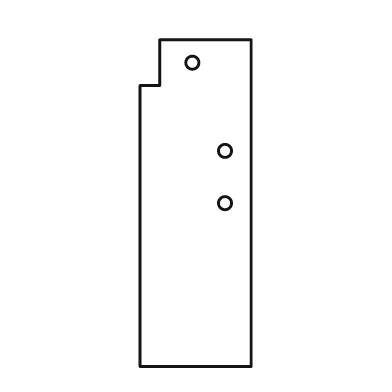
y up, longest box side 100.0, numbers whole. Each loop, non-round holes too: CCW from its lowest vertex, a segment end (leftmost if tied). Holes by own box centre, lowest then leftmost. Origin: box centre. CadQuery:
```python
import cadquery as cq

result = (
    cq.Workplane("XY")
    .moveTo(-17.0, -50.0)
    .lineTo(17.0, -50.0)
    .lineTo(17.0, 50.0)
    .lineTo(-11.0, 50.0)
    .lineTo(-11.0, 36.0)
    .lineTo(-17.0, 36.0)
    .close()
    .moveTo(9.0, 0.0)
    .circle(2.0)
    .moveTo(9.0, 16.0)
    .circle(2.0)
    .moveTo(-1.0, 43.0)
    .circle(2.0)
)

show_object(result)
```